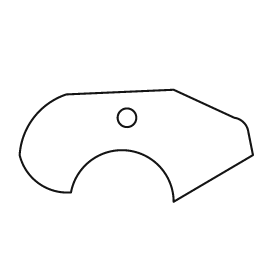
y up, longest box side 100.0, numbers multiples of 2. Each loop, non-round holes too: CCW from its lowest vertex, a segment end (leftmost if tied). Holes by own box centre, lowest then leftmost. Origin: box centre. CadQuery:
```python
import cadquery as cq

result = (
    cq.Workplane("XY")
    .moveTo(16.0, -24.0)
    .lineTo(50.0, -4.0)
    .lineTo(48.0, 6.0)
    .threePointArc((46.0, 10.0), (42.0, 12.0))
    .lineTo(16.0, 24.0)
    .lineTo(-30.0, 22.0)
    .threePointArc((-44.0, 12.0), (-50.0, -4.0))
    .threePointArc((-42.0, -16.0), (-28.0, -20.0))
    .threePointArc((-4.0, -2.0), (16.0, -24.0))
    .close()
    .moveTo(-4.0, 12.0)
    .circle(4.0)
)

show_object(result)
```